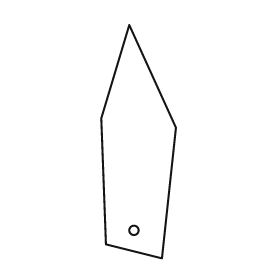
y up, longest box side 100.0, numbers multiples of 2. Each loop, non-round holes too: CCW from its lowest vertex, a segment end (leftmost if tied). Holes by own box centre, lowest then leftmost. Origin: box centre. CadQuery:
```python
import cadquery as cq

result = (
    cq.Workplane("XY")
    .moveTo(10.0, -50.0)
    .lineTo(16.0, 6.0)
    .lineTo(-4.0, 50.0)
    .lineTo(-16.0, 10.0)
    .lineTo(-14.0, -44.0)
    .close()
    .moveTo(-2.0, -38.0)
    .circle(2.0)
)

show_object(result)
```